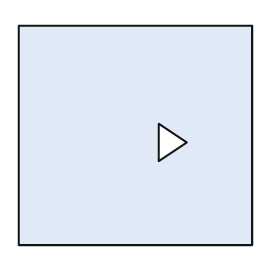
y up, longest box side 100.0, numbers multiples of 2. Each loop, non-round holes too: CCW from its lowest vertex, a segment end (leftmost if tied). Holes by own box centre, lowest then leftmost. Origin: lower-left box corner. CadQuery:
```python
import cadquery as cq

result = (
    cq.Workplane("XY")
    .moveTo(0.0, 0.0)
    .lineTo(100.0, 0.0)
    .lineTo(100.0, 94.0)
    .lineTo(0.0, 94.0)
    .close()
    .moveTo(60.0, 36.0)
    .lineTo(72.0, 44.0)
    .lineTo(60.0, 52.0)
    .close()
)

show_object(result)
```